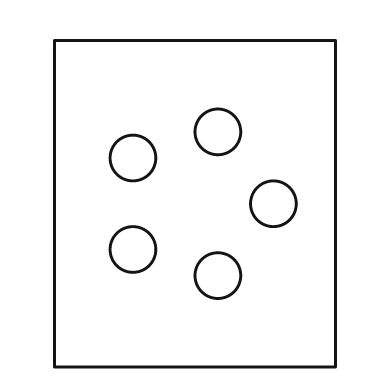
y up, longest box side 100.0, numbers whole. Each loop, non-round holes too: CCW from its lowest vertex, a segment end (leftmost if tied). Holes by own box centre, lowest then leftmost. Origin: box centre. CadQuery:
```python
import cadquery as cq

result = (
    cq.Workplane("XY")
    .moveTo(-43.0, -50.0)
    .lineTo(43.0, -50.0)
    .lineTo(43.0, 50.0)
    .lineTo(-43.0, 50.0)
    .close()
    .moveTo(7.0, -22.0)
    .circle(7.0)
    .moveTo(-19.0, -14.0)
    .circle(7.0)
    .moveTo(24.0, 0.0)
    .circle(7.0)
    .moveTo(-19.0, 14.0)
    .circle(7.0)
    .moveTo(7.0, 22.0)
    .circle(7.0)
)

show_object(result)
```